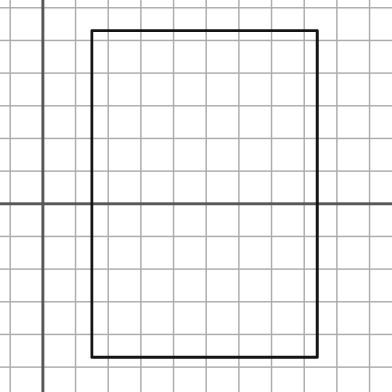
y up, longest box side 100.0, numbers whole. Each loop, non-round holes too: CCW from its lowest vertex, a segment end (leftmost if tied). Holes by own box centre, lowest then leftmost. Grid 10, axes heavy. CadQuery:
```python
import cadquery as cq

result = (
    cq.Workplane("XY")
    .moveTo(15.0, -47.0)
    .lineTo(84.0, -47.0)
    .lineTo(84.0, 53.0)
    .lineTo(15.0, 53.0)
    .close()
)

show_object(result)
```